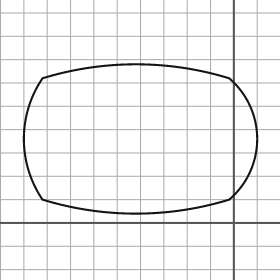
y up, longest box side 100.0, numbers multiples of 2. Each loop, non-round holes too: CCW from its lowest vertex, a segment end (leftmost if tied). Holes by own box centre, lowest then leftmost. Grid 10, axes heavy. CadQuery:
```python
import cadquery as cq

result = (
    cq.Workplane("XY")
    .moveTo(-82.0, 10.0)
    .threePointArc((-42.0, 4.0), (-2.0, 10.0))
    .threePointArc((10.0, 36.0), (-2.0, 62.0))
    .threePointArc((-42.0, 68.0), (-82.0, 62.0))
    .threePointArc((-90.0, 36.0), (-82.0, 10.0))
    .close()
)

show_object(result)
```